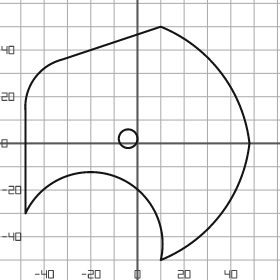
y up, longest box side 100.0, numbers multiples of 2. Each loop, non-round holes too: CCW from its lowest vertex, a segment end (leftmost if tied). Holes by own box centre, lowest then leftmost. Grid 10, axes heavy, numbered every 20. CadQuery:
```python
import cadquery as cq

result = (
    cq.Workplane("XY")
    .moveTo(10.0, -50.0)
    .threePointArc((36.0, -30.0), (48.0, 0.0))
    .threePointArc((36.0, 30.0), (10.0, 50.0))
    .lineTo(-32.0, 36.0)
    .threePointArc((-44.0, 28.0), (-48.0, 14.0))
    .lineTo(-48.0, -30.0)
    .threePointArc((-10.0, -14.0), (10.0, -50.0))
    .close()
    .moveTo(-4.0, 2.0)
    .circle(4.0)
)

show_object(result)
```